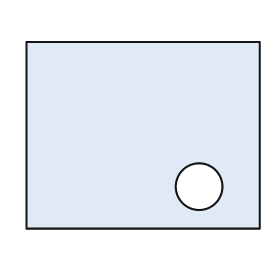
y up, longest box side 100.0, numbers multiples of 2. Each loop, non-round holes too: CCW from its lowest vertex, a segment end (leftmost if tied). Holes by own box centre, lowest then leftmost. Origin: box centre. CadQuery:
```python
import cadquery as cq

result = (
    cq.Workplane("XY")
    .moveTo(-50.0, -40.0)
    .lineTo(50.0, -40.0)
    .lineTo(50.0, 40.0)
    .lineTo(-50.0, 40.0)
    .close()
    .moveTo(24.0, -22.0)
    .circle(10.0)
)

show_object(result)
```